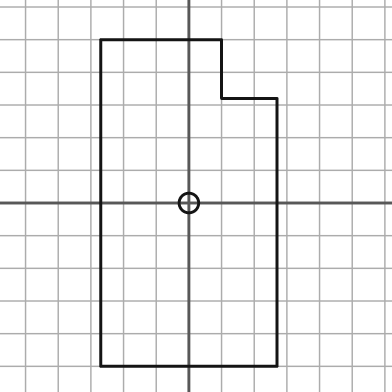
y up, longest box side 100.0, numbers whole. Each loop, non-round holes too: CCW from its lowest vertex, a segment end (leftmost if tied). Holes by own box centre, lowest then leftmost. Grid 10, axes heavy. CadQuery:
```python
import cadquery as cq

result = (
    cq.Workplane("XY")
    .moveTo(-27.0, -50.0)
    .lineTo(27.0, -50.0)
    .lineTo(27.0, 32.0)
    .lineTo(10.0, 32.0)
    .lineTo(10.0, 50.0)
    .lineTo(-27.0, 50.0)
    .close()
    .moveTo(0.0, 0.0)
    .circle(3.0)
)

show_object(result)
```